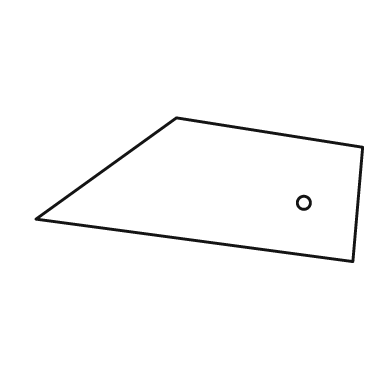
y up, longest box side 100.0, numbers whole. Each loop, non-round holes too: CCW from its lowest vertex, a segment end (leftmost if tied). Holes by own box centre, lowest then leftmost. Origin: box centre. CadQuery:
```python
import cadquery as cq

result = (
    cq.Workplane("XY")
    .moveTo(47.0, -22.0)
    .lineTo(50.0, 13.0)
    .lineTo(-7.0, 22.0)
    .lineTo(-50.0, -9.0)
    .close()
    .moveTo(32.0, -4.0)
    .circle(2.0)
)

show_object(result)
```